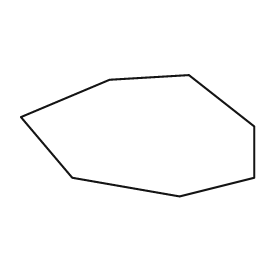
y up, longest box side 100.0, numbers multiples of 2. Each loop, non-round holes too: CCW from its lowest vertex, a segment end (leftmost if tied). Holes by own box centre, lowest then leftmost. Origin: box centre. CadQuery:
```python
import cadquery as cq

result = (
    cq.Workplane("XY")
    .moveTo(18.0, -26.0)
    .lineTo(50.0, -18.0)
    .lineTo(50.0, 4.0)
    .lineTo(22.0, 26.0)
    .lineTo(-12.0, 24.0)
    .lineTo(-50.0, 8.0)
    .lineTo(-28.0, -18.0)
    .close()
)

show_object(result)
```